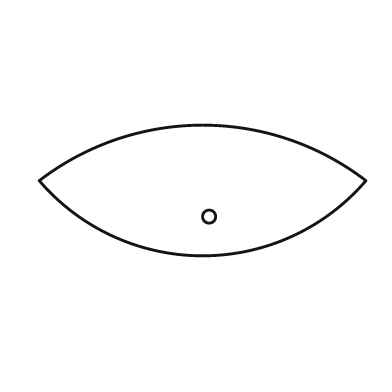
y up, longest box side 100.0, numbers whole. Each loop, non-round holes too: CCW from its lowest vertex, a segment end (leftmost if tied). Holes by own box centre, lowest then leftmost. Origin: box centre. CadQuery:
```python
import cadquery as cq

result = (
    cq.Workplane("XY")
    .moveTo(-50.0, 3.0)
    .threePointArc((0.0, -20.0), (50.0, 3.0))
    .threePointArc((0.0, 20.0), (-50.0, 3.0))
    .close()
    .moveTo(2.0, -8.0)
    .circle(2.0)
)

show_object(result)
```